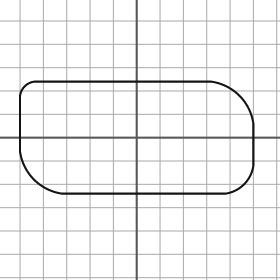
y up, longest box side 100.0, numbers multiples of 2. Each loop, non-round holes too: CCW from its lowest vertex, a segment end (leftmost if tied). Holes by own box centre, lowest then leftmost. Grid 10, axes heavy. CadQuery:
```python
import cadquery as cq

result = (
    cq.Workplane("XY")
    .moveTo(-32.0, -24.0)
    .lineTo(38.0, -24.0)
    .threePointArc((46.0, -20.0), (50.0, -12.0))
    .lineTo(50.0, 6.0)
    .threePointArc((44.0, 18.0), (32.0, 24.0))
    .lineTo(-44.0, 24.0)
    .threePointArc((-48.0, 22.0), (-50.0, 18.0))
    .lineTo(-50.0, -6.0)
    .threePointArc((-44.0, -18.0), (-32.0, -24.0))
    .close()
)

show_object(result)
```